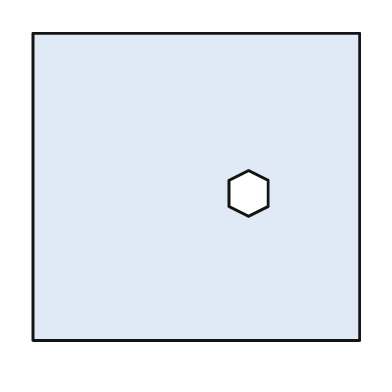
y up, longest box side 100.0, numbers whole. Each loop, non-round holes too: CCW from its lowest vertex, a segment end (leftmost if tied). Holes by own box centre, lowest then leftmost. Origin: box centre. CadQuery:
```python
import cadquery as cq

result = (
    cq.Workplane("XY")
    .moveTo(-50.0, -47.0)
    .lineTo(50.0, -47.0)
    .lineTo(50.0, 47.0)
    .lineTo(-50.0, 47.0)
    .close()
    .moveTo(16.0, -9.0)
    .lineTo(22.0, -6.0)
    .lineTo(22.0, 2.0)
    .lineTo(16.0, 5.0)
    .lineTo(10.0, 2.0)
    .lineTo(10.0, -6.0)
    .close()
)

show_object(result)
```